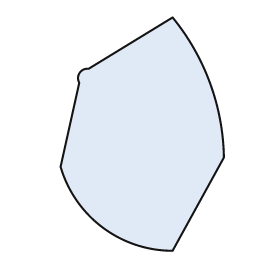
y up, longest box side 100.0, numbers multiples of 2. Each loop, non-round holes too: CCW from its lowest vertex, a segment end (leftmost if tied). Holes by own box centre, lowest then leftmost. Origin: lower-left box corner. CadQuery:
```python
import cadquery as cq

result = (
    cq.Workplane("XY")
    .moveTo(48.0, 0.0)
    .lineTo(70.0, 40.0)
    .threePointArc((64.0, 72.0), (48.0, 100.0))
    .lineTo(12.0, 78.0)
    .threePointArc((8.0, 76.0), (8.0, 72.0))
    .lineTo(0.0, 36.0)
    .threePointArc((18.0, 10.0), (48.0, 0.0))
    .close()
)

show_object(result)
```